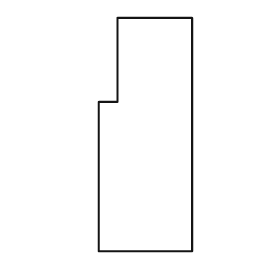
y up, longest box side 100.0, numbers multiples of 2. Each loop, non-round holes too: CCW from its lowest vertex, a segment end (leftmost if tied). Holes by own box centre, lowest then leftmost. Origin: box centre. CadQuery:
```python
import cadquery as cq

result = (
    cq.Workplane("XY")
    .moveTo(-20.0, -50.0)
    .lineTo(20.0, -50.0)
    .lineTo(20.0, 50.0)
    .lineTo(-12.0, 50.0)
    .lineTo(-12.0, 14.0)
    .lineTo(-20.0, 14.0)
    .close()
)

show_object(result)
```